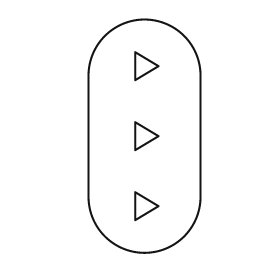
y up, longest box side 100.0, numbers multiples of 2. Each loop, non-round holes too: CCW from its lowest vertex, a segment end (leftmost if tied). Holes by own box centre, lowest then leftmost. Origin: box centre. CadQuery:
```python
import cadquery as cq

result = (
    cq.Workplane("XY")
    .moveTo(-24.0, -26.0)
    .threePointArc((0.0, -50.0), (24.0, -26.0))
    .lineTo(24.0, 26.0)
    .threePointArc((0.0, 50.0), (-24.0, 26.0))
    .close()
    .moveTo(-4.0, -36.0)
    .lineTo(6.0, -30.0)
    .lineTo(-4.0, -24.0)
    .close()
    .moveTo(-4.0, -6.0)
    .lineTo(6.0, 0.0)
    .lineTo(-4.0, 6.0)
    .close()
    .moveTo(-4.0, 24.0)
    .lineTo(6.0, 30.0)
    .lineTo(-4.0, 36.0)
    .close()
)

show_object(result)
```